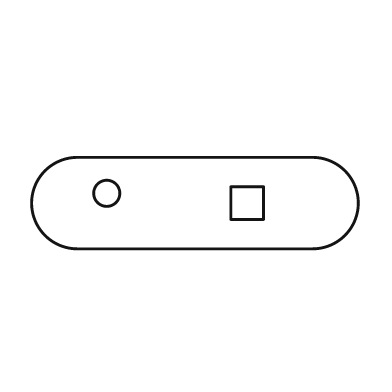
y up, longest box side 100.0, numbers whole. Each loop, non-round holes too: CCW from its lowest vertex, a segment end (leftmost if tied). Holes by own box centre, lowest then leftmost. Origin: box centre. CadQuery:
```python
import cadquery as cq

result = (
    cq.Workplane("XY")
    .moveTo(-36.0, -14.0)
    .lineTo(36.0, -14.0)
    .threePointArc((50.0, 0.0), (36.0, 14.0))
    .lineTo(-36.0, 14.0)
    .threePointArc((-50.0, 0.0), (-36.0, -14.0))
    .close()
    .moveTo(11.0, -5.0)
    .lineTo(21.0, -5.0)
    .lineTo(21.0, 5.0)
    .lineTo(11.0, 5.0)
    .close()
    .moveTo(-27.0, 3.0)
    .circle(4.0)
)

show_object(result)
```